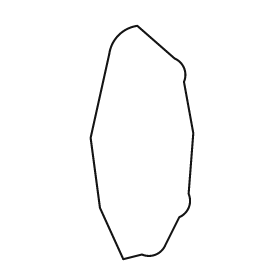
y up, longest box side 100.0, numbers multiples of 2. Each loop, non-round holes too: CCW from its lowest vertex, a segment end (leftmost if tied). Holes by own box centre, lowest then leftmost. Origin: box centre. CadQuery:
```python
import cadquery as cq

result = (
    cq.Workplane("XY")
    .moveTo(-8.0, -50.0)
    .lineTo(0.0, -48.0)
    .threePointArc((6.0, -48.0), (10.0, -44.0))
    .lineTo(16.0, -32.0)
    .threePointArc((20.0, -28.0), (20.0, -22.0))
    .lineTo(22.0, 4.0)
    .lineTo(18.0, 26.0)
    .threePointArc((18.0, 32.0), (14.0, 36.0))
    .lineTo(-2.0, 50.0)
    .threePointArc((-10.0, 46.0), (-14.0, 38.0))
    .lineTo(-22.0, 2.0)
    .lineTo(-18.0, -28.0)
    .close()
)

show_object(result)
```